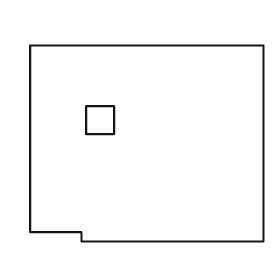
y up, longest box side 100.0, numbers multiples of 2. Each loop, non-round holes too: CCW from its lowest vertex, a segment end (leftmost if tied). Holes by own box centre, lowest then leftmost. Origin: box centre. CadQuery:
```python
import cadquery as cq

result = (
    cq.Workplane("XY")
    .moveTo(-28.0, -42.0)
    .lineTo(50.0, -42.0)
    .lineTo(50.0, 42.0)
    .lineTo(-50.0, 42.0)
    .lineTo(-50.0, -38.0)
    .lineTo(-28.0, -38.0)
    .close()
    .moveTo(-26.0, 4.0)
    .lineTo(-14.0, 4.0)
    .lineTo(-14.0, 16.0)
    .lineTo(-26.0, 16.0)
    .close()
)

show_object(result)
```